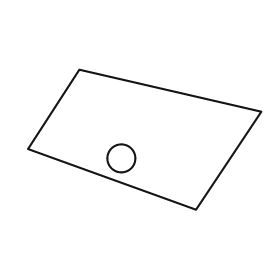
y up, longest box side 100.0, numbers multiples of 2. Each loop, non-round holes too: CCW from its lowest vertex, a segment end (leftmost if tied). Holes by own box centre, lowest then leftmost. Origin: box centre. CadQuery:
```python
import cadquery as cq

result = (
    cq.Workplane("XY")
    .moveTo(22.0, -30.0)
    .lineTo(50.0, 12.0)
    .lineTo(-28.0, 30.0)
    .lineTo(-50.0, -4.0)
    .close()
    .moveTo(-10.0, -8.0)
    .circle(6.0)
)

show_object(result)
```